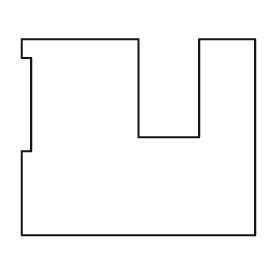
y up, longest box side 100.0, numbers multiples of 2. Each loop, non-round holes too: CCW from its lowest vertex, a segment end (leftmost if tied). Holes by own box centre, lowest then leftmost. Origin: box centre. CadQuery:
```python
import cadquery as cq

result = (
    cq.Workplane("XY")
    .moveTo(-50.0, -42.0)
    .lineTo(50.0, -42.0)
    .lineTo(50.0, 42.0)
    .lineTo(26.0, 42.0)
    .lineTo(26.0, 0.0)
    .lineTo(0.0, 0.0)
    .lineTo(0.0, 42.0)
    .lineTo(-50.0, 42.0)
    .lineTo(-50.0, 34.0)
    .lineTo(-46.0, 34.0)
    .lineTo(-46.0, -6.0)
    .lineTo(-50.0, -6.0)
    .close()
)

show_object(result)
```